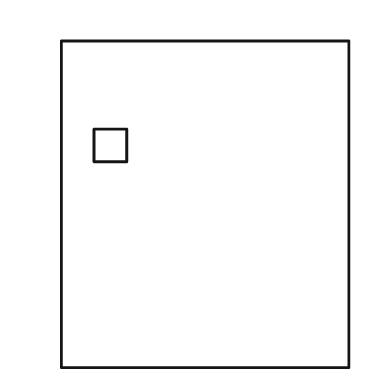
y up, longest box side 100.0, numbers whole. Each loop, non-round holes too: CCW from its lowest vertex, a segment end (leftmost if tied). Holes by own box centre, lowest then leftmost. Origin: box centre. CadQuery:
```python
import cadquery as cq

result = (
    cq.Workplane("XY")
    .moveTo(-44.0, -50.0)
    .lineTo(44.0, -50.0)
    .lineTo(44.0, 50.0)
    .lineTo(-44.0, 50.0)
    .close()
    .moveTo(-34.0, 13.0)
    .lineTo(-24.0, 13.0)
    .lineTo(-24.0, 23.0)
    .lineTo(-34.0, 23.0)
    .close()
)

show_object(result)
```